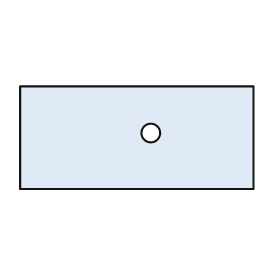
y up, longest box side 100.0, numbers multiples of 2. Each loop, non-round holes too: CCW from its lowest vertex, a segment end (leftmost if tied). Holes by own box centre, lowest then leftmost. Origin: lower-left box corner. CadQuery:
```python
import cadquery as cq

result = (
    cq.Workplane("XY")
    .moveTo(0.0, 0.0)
    .lineTo(100.0, 0.0)
    .lineTo(100.0, 44.0)
    .lineTo(0.0, 44.0)
    .close()
    .moveTo(56.0, 24.0)
    .circle(4.0)
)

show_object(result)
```